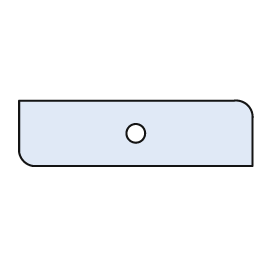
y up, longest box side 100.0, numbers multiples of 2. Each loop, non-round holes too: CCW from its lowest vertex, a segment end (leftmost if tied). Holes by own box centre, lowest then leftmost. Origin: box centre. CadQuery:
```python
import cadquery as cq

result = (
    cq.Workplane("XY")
    .moveTo(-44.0, -14.0)
    .lineTo(50.0, -14.0)
    .lineTo(50.0, 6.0)
    .threePointArc((48.0, 12.0), (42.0, 14.0))
    .lineTo(-50.0, 14.0)
    .lineTo(-50.0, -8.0)
    .threePointArc((-48.0, -12.0), (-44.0, -14.0))
    .close()
    .moveTo(0.0, 0.0)
    .circle(4.0)
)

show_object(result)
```